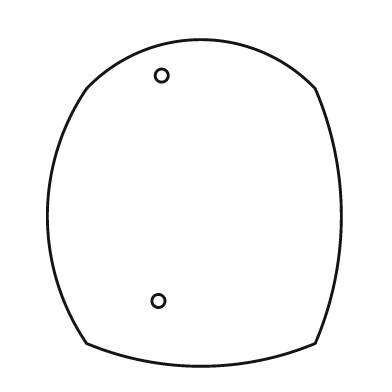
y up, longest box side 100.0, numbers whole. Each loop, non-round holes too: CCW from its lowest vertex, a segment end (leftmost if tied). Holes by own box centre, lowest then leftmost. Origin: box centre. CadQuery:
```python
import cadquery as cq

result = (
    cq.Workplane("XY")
    .moveTo(-33.0, -43.0)
    .threePointArc((2.0, -50.0), (37.0, -43.0))
    .threePointArc((45.0, -4.0), (37.0, 35.0))
    .threePointArc((2.0, 50.0), (-33.0, 35.0))
    .threePointArc((-45.0, -4.0), (-33.0, -43.0))
    .close()
    .moveTo(-11.0, -30.0)
    .circle(2.0)
    .moveTo(-10.0, 39.0)
    .circle(2.0)
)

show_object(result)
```